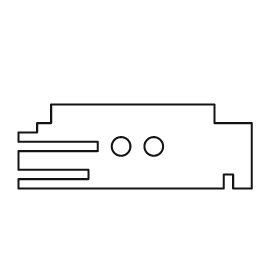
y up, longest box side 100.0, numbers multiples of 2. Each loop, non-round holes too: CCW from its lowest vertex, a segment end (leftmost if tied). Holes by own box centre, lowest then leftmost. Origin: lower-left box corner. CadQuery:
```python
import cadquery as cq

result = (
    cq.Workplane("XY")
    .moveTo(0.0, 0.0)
    .lineTo(88.0, 0.0)
    .lineTo(88.0, 6.0)
    .lineTo(92.0, 6.0)
    .lineTo(92.0, 0.0)
    .lineTo(100.0, 0.0)
    .lineTo(100.0, 28.0)
    .lineTo(84.0, 28.0)
    .lineTo(84.0, 36.0)
    .lineTo(14.0, 36.0)
    .lineTo(14.0, 28.0)
    .lineTo(8.0, 28.0)
    .lineTo(8.0, 24.0)
    .lineTo(0.0, 24.0)
    .lineTo(0.0, 20.0)
    .lineTo(34.0, 20.0)
    .lineTo(34.0, 16.0)
    .lineTo(0.0, 16.0)
    .lineTo(0.0, 8.0)
    .lineTo(30.0, 8.0)
    .lineTo(30.0, 4.0)
    .lineTo(0.0, 4.0)
    .close()
    .moveTo(44.0, 18.0)
    .circle(4.0)
    .moveTo(58.0, 18.0)
    .circle(4.0)
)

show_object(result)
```